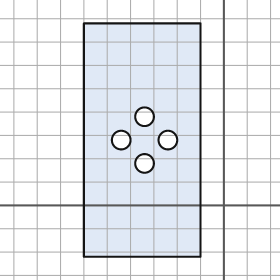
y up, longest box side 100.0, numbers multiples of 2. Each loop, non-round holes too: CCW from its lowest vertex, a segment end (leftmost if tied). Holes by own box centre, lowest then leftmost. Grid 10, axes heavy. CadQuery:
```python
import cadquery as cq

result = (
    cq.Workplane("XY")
    .moveTo(-60.0, -22.0)
    .lineTo(-10.0, -22.0)
    .lineTo(-10.0, 78.0)
    .lineTo(-60.0, 78.0)
    .close()
    .moveTo(-34.0, 18.0)
    .circle(4.0)
    .moveTo(-44.0, 28.0)
    .circle(4.0)
    .moveTo(-24.0, 28.0)
    .circle(4.0)
    .moveTo(-34.0, 38.0)
    .circle(4.0)
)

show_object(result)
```